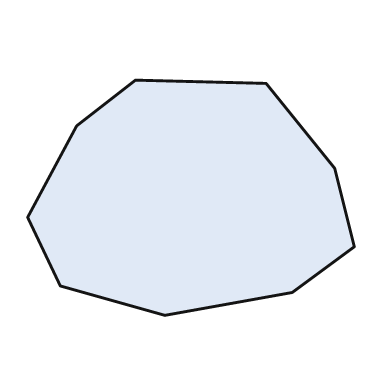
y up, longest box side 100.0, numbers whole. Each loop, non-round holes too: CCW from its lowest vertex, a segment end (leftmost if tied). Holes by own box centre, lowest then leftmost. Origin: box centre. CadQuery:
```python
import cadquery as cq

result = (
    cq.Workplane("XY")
    .moveTo(-8.0, -36.0)
    .lineTo(31.0, -29.0)
    .lineTo(50.0, -15.0)
    .lineTo(44.0, 9.0)
    .lineTo(23.0, 35.0)
    .lineTo(-17.0, 36.0)
    .lineTo(-35.0, 22.0)
    .lineTo(-50.0, -6.0)
    .lineTo(-40.0, -27.0)
    .close()
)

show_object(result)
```